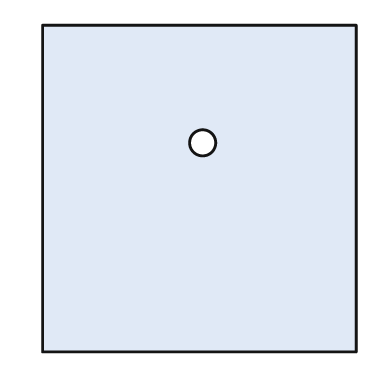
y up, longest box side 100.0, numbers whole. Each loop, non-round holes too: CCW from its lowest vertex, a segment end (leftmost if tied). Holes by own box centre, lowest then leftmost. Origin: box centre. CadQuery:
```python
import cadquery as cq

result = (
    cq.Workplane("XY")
    .moveTo(-48.0, -50.0)
    .lineTo(48.0, -50.0)
    .lineTo(48.0, 50.0)
    .lineTo(-48.0, 50.0)
    .close()
    .moveTo(1.0, 14.0)
    .circle(4.0)
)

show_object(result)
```